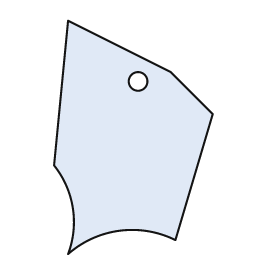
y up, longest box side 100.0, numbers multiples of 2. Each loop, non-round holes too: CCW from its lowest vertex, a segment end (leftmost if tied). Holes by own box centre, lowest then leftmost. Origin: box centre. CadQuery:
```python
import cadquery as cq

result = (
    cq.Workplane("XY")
    .moveTo(-28.0, -50.0)
    .threePointArc((-6.0, -40.0), (18.0, -44.0))
    .lineTo(34.0, 10.0)
    .lineTo(16.0, 28.0)
    .lineTo(-28.0, 50.0)
    .lineTo(-34.0, -12.0)
    .threePointArc((-26.0, -30.0), (-28.0, -50.0))
    .close()
    .moveTo(2.0, 24.0)
    .circle(4.0)
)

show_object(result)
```